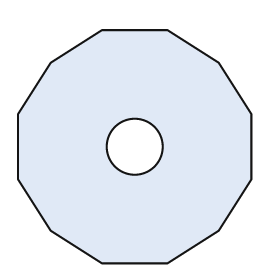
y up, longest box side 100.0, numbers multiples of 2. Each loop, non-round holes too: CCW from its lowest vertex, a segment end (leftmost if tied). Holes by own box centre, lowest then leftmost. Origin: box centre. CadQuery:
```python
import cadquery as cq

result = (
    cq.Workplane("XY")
    .moveTo(-14.0, -50.0)
    .lineTo(14.0, -50.0)
    .lineTo(36.0, -36.0)
    .lineTo(50.0, -14.0)
    .lineTo(50.0, 14.0)
    .lineTo(36.0, 36.0)
    .lineTo(14.0, 50.0)
    .lineTo(-14.0, 50.0)
    .lineTo(-36.0, 36.0)
    .lineTo(-50.0, 14.0)
    .lineTo(-50.0, -14.0)
    .lineTo(-36.0, -36.0)
    .close()
    .moveTo(0.0, 0.0)
    .circle(12.0)
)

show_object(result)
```